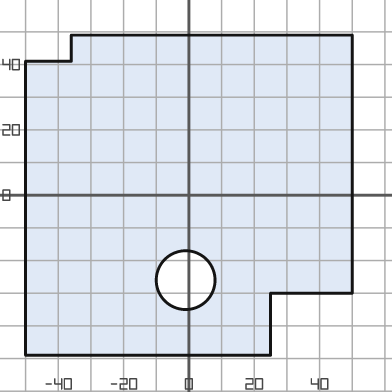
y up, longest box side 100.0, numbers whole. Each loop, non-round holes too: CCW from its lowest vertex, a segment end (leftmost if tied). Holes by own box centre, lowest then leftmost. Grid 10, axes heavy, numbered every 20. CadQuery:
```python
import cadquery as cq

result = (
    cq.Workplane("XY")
    .moveTo(-50.0, -49.0)
    .lineTo(25.0, -49.0)
    .lineTo(25.0, -30.0)
    .lineTo(50.0, -30.0)
    .lineTo(50.0, 49.0)
    .lineTo(-36.0, 49.0)
    .lineTo(-36.0, 41.0)
    .lineTo(-50.0, 41.0)
    .close()
    .moveTo(-1.0, -26.0)
    .circle(9.0)
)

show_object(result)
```